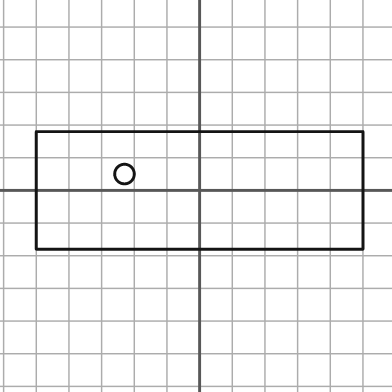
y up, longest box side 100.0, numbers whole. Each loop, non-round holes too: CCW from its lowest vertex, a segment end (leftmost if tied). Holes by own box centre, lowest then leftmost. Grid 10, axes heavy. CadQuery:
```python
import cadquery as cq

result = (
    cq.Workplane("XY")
    .moveTo(-50.0, -18.0)
    .lineTo(50.0, -18.0)
    .lineTo(50.0, 18.0)
    .lineTo(-50.0, 18.0)
    .close()
    .moveTo(-23.0, 5.0)
    .circle(3.0)
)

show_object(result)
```